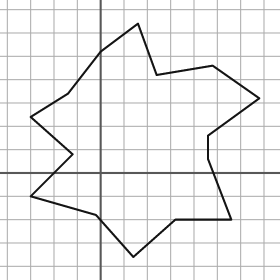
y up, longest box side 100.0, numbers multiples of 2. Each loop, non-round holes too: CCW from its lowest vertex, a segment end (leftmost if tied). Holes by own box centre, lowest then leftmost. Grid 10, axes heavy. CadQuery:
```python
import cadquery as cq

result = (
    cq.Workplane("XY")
    .moveTo(14.0, -36.0)
    .lineTo(32.0, -20.0)
    .lineTo(56.0, -20.0)
    .lineTo(46.0, 6.0)
    .lineTo(46.0, 16.0)
    .lineTo(68.0, 32.0)
    .lineTo(48.0, 46.0)
    .lineTo(24.0, 42.0)
    .lineTo(16.0, 64.0)
    .lineTo(0.0, 52.0)
    .lineTo(-14.0, 34.0)
    .lineTo(-30.0, 24.0)
    .lineTo(-12.0, 8.0)
    .lineTo(-30.0, -10.0)
    .lineTo(-2.0, -18.0)
    .close()
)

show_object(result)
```